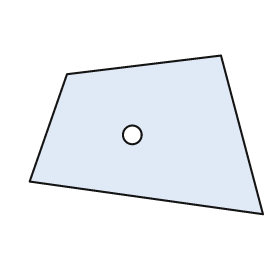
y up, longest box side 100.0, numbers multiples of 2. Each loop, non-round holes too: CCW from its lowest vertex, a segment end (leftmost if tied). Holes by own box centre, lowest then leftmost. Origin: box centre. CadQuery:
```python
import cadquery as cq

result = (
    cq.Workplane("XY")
    .moveTo(50.0, -34.0)
    .lineTo(32.0, 34.0)
    .lineTo(-34.0, 26.0)
    .lineTo(-50.0, -20.0)
    .close()
    .moveTo(-6.0, 0.0)
    .circle(4.0)
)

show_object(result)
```